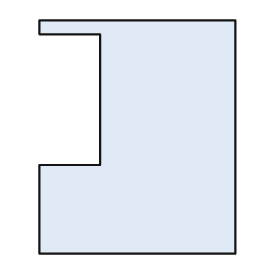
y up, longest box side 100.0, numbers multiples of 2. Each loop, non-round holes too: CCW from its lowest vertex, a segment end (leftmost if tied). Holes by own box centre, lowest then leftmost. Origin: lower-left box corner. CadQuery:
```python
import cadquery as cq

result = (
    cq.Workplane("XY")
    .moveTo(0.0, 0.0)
    .lineTo(84.0, 0.0)
    .lineTo(84.0, 100.0)
    .lineTo(0.0, 100.0)
    .lineTo(0.0, 94.0)
    .lineTo(26.0, 94.0)
    .lineTo(26.0, 38.0)
    .lineTo(0.0, 38.0)
    .close()
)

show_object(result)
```